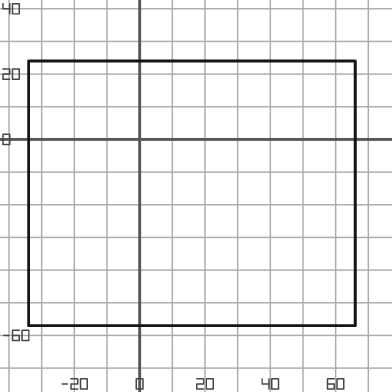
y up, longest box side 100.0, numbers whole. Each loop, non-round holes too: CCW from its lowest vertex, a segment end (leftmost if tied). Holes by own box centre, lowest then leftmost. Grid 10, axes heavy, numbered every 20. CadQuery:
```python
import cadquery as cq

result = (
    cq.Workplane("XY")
    .moveTo(-34.0, -57.0)
    .lineTo(66.0, -57.0)
    .lineTo(66.0, 24.0)
    .lineTo(-34.0, 24.0)
    .close()
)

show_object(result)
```